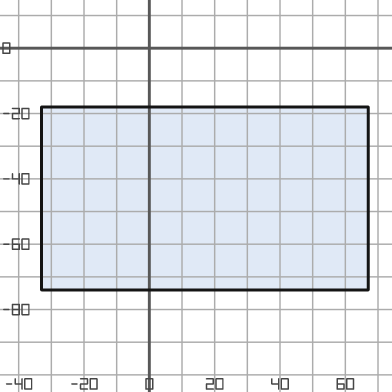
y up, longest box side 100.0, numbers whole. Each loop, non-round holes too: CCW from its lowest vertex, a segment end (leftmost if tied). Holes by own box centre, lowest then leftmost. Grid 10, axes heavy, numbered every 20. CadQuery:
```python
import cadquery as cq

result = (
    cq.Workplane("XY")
    .moveTo(-33.0, -74.0)
    .lineTo(67.0, -74.0)
    .lineTo(67.0, -18.0)
    .lineTo(-33.0, -18.0)
    .close()
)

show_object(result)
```